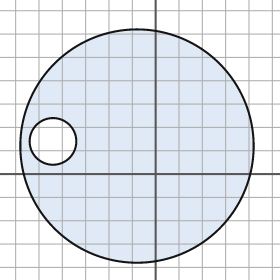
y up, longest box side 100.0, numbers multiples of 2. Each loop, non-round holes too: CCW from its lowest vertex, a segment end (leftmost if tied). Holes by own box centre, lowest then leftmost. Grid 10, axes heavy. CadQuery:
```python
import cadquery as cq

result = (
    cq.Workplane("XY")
    .moveTo(-8.0, 12.0)
    .circle(50.0)
    .moveTo(-44.0, 14.0)
    .circle(10.0)
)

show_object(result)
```